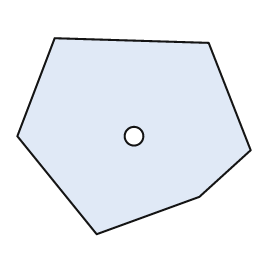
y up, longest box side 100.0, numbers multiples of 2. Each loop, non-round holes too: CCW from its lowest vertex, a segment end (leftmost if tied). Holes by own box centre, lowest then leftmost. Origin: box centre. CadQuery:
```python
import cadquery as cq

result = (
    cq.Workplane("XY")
    .moveTo(-16.0, -42.0)
    .lineTo(28.0, -26.0)
    .lineTo(50.0, -6.0)
    .lineTo(32.0, 40.0)
    .lineTo(-34.0, 42.0)
    .lineTo(-50.0, 0.0)
    .close()
    .moveTo(0.0, 0.0)
    .circle(4.0)
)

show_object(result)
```